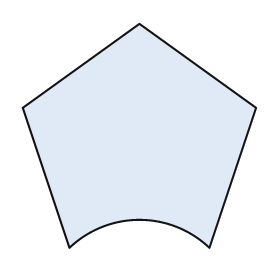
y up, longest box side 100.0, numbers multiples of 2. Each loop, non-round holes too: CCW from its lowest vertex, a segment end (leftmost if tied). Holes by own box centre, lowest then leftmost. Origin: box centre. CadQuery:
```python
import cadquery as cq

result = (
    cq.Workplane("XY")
    .moveTo(-30.0, -48.0)
    .threePointArc((0.0, -36.0), (30.0, -48.0))
    .lineTo(50.0, 12.0)
    .lineTo(0.0, 48.0)
    .lineTo(-50.0, 12.0)
    .close()
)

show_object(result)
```